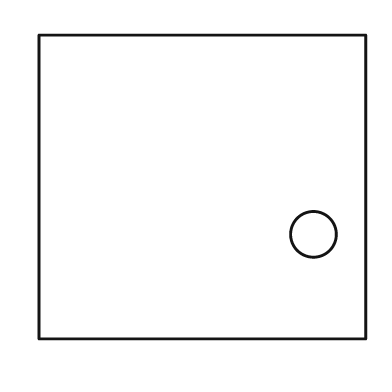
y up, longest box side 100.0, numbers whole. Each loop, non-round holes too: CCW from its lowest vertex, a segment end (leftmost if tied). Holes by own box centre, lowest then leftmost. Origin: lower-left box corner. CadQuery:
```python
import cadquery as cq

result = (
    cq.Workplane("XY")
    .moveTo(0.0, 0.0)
    .lineTo(100.0, 0.0)
    .lineTo(100.0, 93.0)
    .lineTo(0.0, 93.0)
    .close()
    .moveTo(84.0, 32.0)
    .circle(7.0)
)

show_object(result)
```